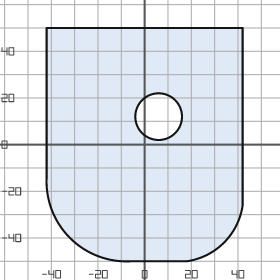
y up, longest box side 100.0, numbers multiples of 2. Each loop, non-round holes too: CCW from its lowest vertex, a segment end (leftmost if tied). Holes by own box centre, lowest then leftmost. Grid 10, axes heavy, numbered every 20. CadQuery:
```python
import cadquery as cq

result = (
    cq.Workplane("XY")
    .moveTo(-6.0, -50.0)
    .lineTo(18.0, -50.0)
    .threePointArc((34.0, -42.0), (42.0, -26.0))
    .lineTo(42.0, 50.0)
    .lineTo(-42.0, 50.0)
    .lineTo(-42.0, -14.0)
    .threePointArc((-32.0, -40.0), (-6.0, -50.0))
    .close()
    .moveTo(6.0, 12.0)
    .circle(10.0)
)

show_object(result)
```